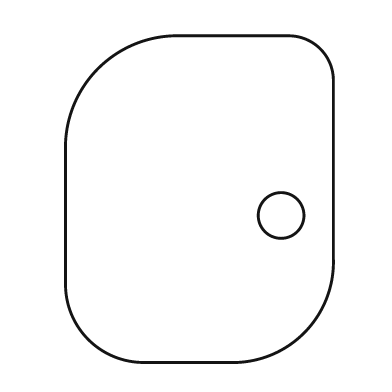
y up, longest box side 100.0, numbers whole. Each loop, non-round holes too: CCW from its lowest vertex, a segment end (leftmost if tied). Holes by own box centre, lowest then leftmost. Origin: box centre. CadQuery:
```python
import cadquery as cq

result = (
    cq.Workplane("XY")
    .moveTo(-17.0, -50.0)
    .lineTo(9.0, -50.0)
    .threePointArc((32.0, -41.0), (41.0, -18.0))
    .lineTo(41.0, 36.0)
    .threePointArc((37.0, 46.0), (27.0, 50.0))
    .lineTo(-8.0, 50.0)
    .threePointArc((-31.0, 40.0), (-41.0, 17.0))
    .lineTo(-41.0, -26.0)
    .threePointArc((-34.0, -43.0), (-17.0, -50.0))
    .close()
    .moveTo(25.0, -5.0)
    .circle(7.0)
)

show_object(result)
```